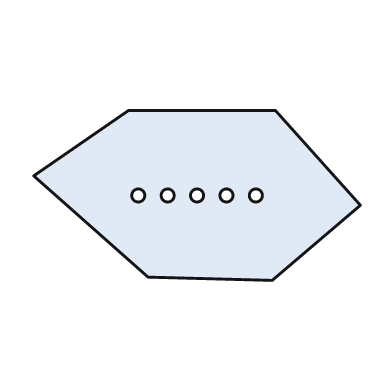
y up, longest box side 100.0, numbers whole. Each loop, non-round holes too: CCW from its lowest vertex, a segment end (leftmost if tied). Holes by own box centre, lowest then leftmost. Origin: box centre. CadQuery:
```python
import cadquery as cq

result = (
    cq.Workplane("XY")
    .moveTo(23.0, -26.0)
    .lineTo(50.0, -3.0)
    .lineTo(24.0, 26.0)
    .lineTo(-21.0, 26.0)
    .lineTo(-50.0, 6.0)
    .lineTo(-15.0, -25.0)
    .close()
    .moveTo(-18.0, 0.0)
    .circle(2.0)
    .moveTo(-9.0, 0.0)
    .circle(2.0)
    .moveTo(0.0, 0.0)
    .circle(2.0)
    .moveTo(9.0, 0.0)
    .circle(2.0)
    .moveTo(18.0, 0.0)
    .circle(2.0)
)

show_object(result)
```